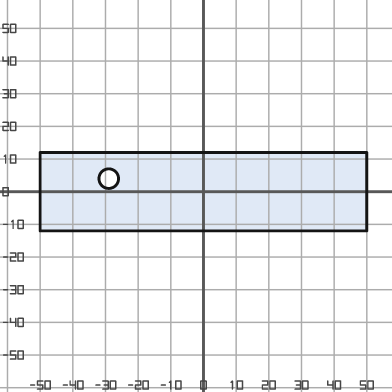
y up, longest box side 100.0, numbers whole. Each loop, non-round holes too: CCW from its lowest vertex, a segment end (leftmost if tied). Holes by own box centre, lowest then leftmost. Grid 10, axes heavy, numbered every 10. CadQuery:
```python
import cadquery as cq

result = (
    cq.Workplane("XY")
    .moveTo(-50.0, -12.0)
    .lineTo(50.0, -12.0)
    .lineTo(50.0, 12.0)
    .lineTo(-50.0, 12.0)
    .close()
    .moveTo(-29.0, 4.0)
    .circle(3.0)
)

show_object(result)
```